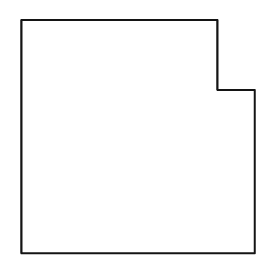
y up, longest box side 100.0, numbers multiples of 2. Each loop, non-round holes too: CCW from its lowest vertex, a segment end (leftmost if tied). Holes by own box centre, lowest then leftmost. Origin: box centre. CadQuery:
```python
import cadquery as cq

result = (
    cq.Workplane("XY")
    .moveTo(-50.0, -50.0)
    .lineTo(50.0, -50.0)
    .lineTo(50.0, 20.0)
    .lineTo(34.0, 20.0)
    .lineTo(34.0, 50.0)
    .lineTo(-50.0, 50.0)
    .close()
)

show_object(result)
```